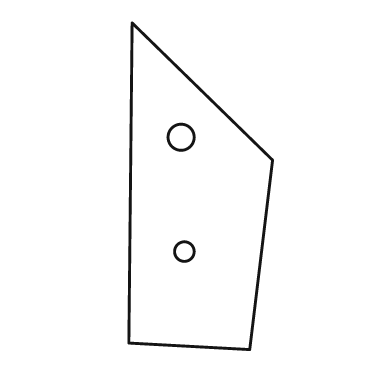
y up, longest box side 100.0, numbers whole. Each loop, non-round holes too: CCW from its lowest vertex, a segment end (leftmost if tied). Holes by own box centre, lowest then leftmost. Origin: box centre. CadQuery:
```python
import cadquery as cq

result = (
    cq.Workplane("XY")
    .moveTo(15.0, -50.0)
    .lineTo(22.0, 8.0)
    .lineTo(-21.0, 50.0)
    .lineTo(-22.0, -48.0)
    .close()
    .moveTo(-5.0, -20.0)
    .circle(3.0)
    .moveTo(-6.0, 15.0)
    .circle(4.0)
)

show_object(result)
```